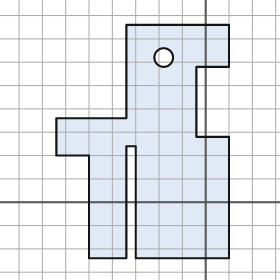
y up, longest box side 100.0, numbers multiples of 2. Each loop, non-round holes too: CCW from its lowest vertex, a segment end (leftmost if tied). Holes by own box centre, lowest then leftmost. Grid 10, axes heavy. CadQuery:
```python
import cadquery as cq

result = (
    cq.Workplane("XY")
    .moveTo(-50.0, -24.0)
    .lineTo(-34.0, -24.0)
    .lineTo(-34.0, 24.0)
    .lineTo(-30.0, 24.0)
    .lineTo(-30.0, -24.0)
    .lineTo(10.0, -24.0)
    .lineTo(10.0, 28.0)
    .lineTo(-4.0, 28.0)
    .lineTo(-4.0, 58.0)
    .lineTo(10.0, 58.0)
    .lineTo(10.0, 76.0)
    .lineTo(-34.0, 76.0)
    .lineTo(-34.0, 36.0)
    .lineTo(-64.0, 36.0)
    .lineTo(-64.0, 20.0)
    .lineTo(-50.0, 20.0)
    .close()
    .moveTo(-18.0, 62.0)
    .circle(4.0)
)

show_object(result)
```